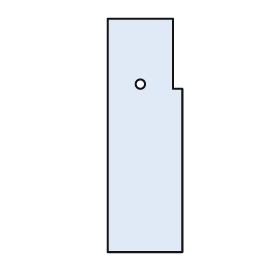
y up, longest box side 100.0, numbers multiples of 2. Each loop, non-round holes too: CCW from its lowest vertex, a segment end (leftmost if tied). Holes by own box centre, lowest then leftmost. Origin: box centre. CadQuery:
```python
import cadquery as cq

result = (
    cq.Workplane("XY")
    .moveTo(-16.0, -50.0)
    .lineTo(16.0, -50.0)
    .lineTo(16.0, 20.0)
    .lineTo(12.0, 20.0)
    .lineTo(12.0, 50.0)
    .lineTo(-16.0, 50.0)
    .close()
    .moveTo(-2.0, 22.0)
    .circle(2.0)
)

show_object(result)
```